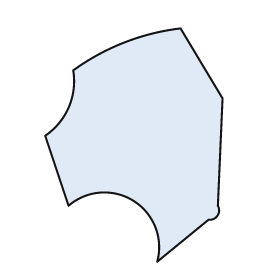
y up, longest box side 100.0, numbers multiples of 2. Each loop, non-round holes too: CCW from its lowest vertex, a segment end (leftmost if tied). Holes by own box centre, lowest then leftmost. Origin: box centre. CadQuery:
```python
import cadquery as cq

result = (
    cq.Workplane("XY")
    .moveTo(10.0, -50.0)
    .lineTo(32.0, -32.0)
    .threePointArc((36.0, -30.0), (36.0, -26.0))
    .lineTo(38.0, 20.0)
    .lineTo(20.0, 50.0)
    .threePointArc((-4.0, 44.0), (-26.0, 32.0))
    .threePointArc((-28.0, 16.0), (-38.0, 4.0))
    .lineTo(-28.0, -26.0)
    .threePointArc((0.0, -24.0), (10.0, -50.0))
    .close()
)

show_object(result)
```